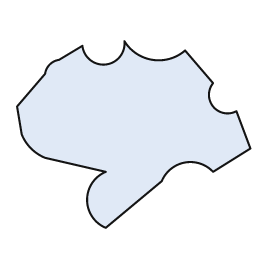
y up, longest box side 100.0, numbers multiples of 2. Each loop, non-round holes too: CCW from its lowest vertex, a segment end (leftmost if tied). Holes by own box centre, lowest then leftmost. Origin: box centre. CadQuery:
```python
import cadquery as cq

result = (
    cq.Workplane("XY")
    .moveTo(-12.0, -40.0)
    .lineTo(12.0, -20.0)
    .threePointArc((22.0, -12.0), (34.0, -16.0))
    .lineTo(50.0, -6.0)
    .lineTo(44.0, 10.0)
    .threePointArc((34.0, 12.0), (34.0, 22.0))
    .lineTo(22.0, 36.0)
    .threePointArc((8.0, 32.0), (-4.0, 40.0))
    .threePointArc((-12.0, 30.0), (-22.0, 38.0))
    .lineTo(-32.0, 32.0)
    .threePointArc((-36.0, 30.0), (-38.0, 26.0))
    .lineTo(-50.0, 12.0)
    .lineTo(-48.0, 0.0)
    .threePointArc((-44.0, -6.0), (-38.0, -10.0))
    .lineTo(-12.0, -16.0)
    .threePointArc((-20.0, -28.0), (-12.0, -40.0))
    .close()
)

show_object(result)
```